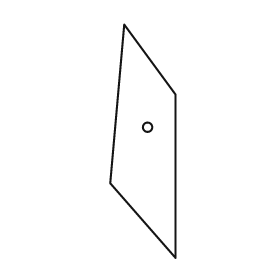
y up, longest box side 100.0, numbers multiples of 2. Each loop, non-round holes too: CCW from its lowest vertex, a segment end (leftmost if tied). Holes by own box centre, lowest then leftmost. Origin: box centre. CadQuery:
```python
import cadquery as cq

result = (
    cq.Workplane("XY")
    .moveTo(14.0, -50.0)
    .lineTo(14.0, 20.0)
    .lineTo(-8.0, 50.0)
    .lineTo(-14.0, -18.0)
    .close()
    .moveTo(2.0, 6.0)
    .circle(2.0)
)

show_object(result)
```